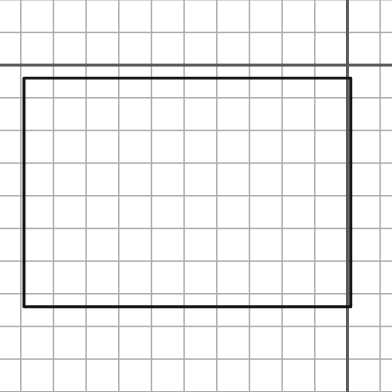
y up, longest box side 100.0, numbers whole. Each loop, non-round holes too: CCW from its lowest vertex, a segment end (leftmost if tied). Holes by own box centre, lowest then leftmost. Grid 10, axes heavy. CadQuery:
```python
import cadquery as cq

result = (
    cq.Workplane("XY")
    .moveTo(-99.0, -74.0)
    .lineTo(1.0, -74.0)
    .lineTo(1.0, -4.0)
    .lineTo(-99.0, -4.0)
    .close()
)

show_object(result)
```